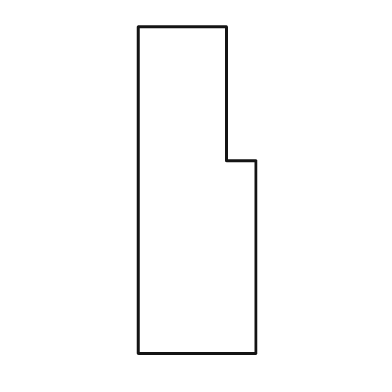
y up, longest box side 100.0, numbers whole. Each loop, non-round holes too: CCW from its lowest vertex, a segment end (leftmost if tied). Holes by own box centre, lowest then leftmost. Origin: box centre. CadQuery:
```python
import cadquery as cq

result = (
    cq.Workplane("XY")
    .moveTo(-18.0, -50.0)
    .lineTo(18.0, -50.0)
    .lineTo(18.0, 9.0)
    .lineTo(9.0, 9.0)
    .lineTo(9.0, 50.0)
    .lineTo(-18.0, 50.0)
    .close()
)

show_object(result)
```